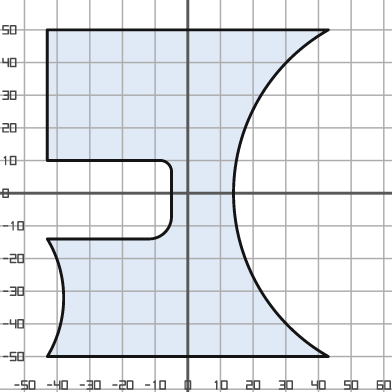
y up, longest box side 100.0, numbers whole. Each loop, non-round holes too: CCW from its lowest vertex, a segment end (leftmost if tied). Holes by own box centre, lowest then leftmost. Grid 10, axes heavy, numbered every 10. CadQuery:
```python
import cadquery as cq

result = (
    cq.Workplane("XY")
    .moveTo(-43.0, -50.0)
    .lineTo(43.0, -50.0)
    .threePointArc((14.0, 0.0), (43.0, 50.0))
    .lineTo(-43.0, 50.0)
    .lineTo(-43.0, 10.0)
    .lineTo(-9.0, 10.0)
    .threePointArc((-6.0, 9.0), (-5.0, 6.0))
    .lineTo(-5.0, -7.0)
    .threePointArc((-7.0, -12.0), (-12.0, -14.0))
    .lineTo(-43.0, -14.0)
    .threePointArc((-38.0, -32.0), (-43.0, -50.0))
    .close()
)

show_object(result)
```